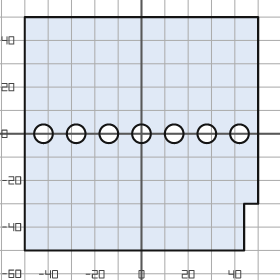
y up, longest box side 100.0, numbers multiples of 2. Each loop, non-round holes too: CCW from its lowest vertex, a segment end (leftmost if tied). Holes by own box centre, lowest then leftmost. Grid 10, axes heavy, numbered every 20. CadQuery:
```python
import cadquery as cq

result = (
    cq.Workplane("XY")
    .moveTo(-50.0, -50.0)
    .lineTo(44.0, -50.0)
    .lineTo(44.0, -30.0)
    .lineTo(50.0, -30.0)
    .lineTo(50.0, 50.0)
    .lineTo(-50.0, 50.0)
    .close()
    .moveTo(-42.0, 0.0)
    .circle(4.0)
    .moveTo(-28.0, 0.0)
    .circle(4.0)
    .moveTo(-14.0, 0.0)
    .circle(4.0)
    .moveTo(0.0, 0.0)
    .circle(4.0)
    .moveTo(14.0, 0.0)
    .circle(4.0)
    .moveTo(28.0, 0.0)
    .circle(4.0)
    .moveTo(42.0, 0.0)
    .circle(4.0)
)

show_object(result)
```